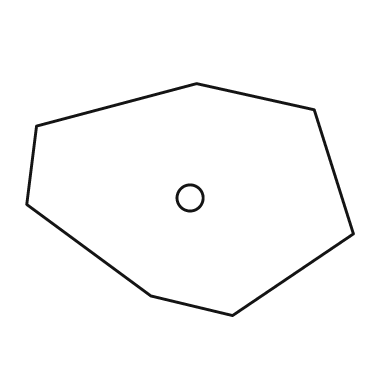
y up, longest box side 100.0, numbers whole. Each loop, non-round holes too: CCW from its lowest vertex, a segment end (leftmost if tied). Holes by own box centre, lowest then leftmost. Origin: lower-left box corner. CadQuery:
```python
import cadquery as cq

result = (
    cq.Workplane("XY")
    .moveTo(63.0, 0.0)
    .lineTo(100.0, 25.0)
    .lineTo(88.0, 63.0)
    .lineTo(52.0, 71.0)
    .lineTo(3.0, 58.0)
    .lineTo(0.0, 34.0)
    .lineTo(38.0, 6.0)
    .close()
    .moveTo(50.0, 36.0)
    .circle(4.0)
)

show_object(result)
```